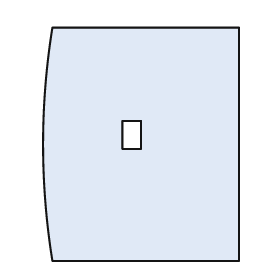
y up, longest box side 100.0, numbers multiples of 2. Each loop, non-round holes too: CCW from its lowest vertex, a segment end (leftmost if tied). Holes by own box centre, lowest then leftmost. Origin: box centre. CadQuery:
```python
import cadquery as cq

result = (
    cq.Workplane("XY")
    .moveTo(-38.0, -50.0)
    .lineTo(42.0, -50.0)
    .lineTo(42.0, 50.0)
    .lineTo(-38.0, 50.0)
    .threePointArc((-42.0, 0.0), (-38.0, -50.0))
    .close()
    .moveTo(-8.0, -2.0)
    .lineTo(0.0, -2.0)
    .lineTo(0.0, 10.0)
    .lineTo(-8.0, 10.0)
    .close()
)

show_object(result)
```